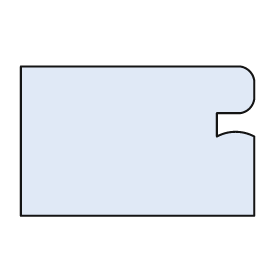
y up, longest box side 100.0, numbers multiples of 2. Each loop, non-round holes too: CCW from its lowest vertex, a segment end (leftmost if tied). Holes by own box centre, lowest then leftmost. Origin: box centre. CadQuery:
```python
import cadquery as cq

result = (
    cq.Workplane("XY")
    .moveTo(-50.0, -32.0)
    .lineTo(50.0, -32.0)
    .lineTo(50.0, 2.0)
    .threePointArc((42.0, 4.0), (34.0, 2.0))
    .lineTo(34.0, 12.0)
    .lineTo(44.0, 12.0)
    .threePointArc((48.0, 14.0), (50.0, 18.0))
    .lineTo(50.0, 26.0)
    .threePointArc((48.0, 30.0), (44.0, 32.0))
    .lineTo(-50.0, 32.0)
    .close()
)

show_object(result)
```